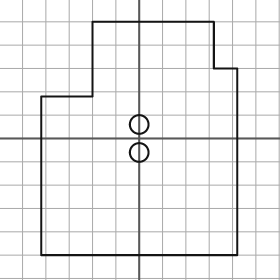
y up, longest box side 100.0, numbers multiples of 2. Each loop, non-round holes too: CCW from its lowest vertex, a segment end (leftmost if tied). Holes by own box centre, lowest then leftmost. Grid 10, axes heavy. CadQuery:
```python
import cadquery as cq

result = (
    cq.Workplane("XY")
    .moveTo(-42.0, -50.0)
    .lineTo(42.0, -50.0)
    .lineTo(42.0, 30.0)
    .lineTo(32.0, 30.0)
    .lineTo(32.0, 50.0)
    .lineTo(-20.0, 50.0)
    .lineTo(-20.0, 18.0)
    .lineTo(-42.0, 18.0)
    .close()
    .moveTo(0.0, -6.0)
    .circle(4.0)
    .moveTo(0.0, 6.0)
    .circle(4.0)
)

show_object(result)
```